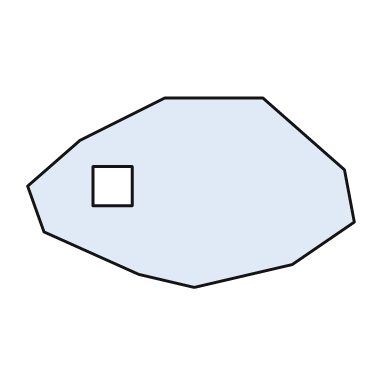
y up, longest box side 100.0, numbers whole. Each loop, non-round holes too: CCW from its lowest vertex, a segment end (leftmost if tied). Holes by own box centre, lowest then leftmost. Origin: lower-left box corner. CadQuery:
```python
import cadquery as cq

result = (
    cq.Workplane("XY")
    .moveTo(51.0, 0.0)
    .lineTo(81.0, 7.0)
    .lineTo(100.0, 20.0)
    .lineTo(97.0, 36.0)
    .lineTo(72.0, 58.0)
    .lineTo(42.0, 58.0)
    .lineTo(16.0, 45.0)
    .lineTo(0.0, 31.0)
    .lineTo(5.0, 17.0)
    .lineTo(34.0, 4.0)
    .close()
    .moveTo(20.0, 25.0)
    .lineTo(32.0, 25.0)
    .lineTo(32.0, 37.0)
    .lineTo(20.0, 37.0)
    .close()
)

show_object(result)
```